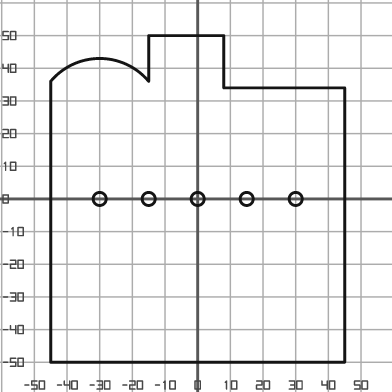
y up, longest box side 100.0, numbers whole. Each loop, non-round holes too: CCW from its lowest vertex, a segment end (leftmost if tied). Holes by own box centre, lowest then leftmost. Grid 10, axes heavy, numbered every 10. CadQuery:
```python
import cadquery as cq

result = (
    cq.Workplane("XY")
    .moveTo(-45.0, -50.0)
    .lineTo(45.0, -50.0)
    .lineTo(45.0, 34.0)
    .lineTo(8.0, 34.0)
    .lineTo(8.0, 50.0)
    .lineTo(-15.0, 50.0)
    .lineTo(-15.0, 36.0)
    .threePointArc((-30.0, 43.0), (-45.0, 36.0))
    .close()
    .moveTo(-30.0, 0.0)
    .circle(2.0)
    .moveTo(-15.0, 0.0)
    .circle(2.0)
    .moveTo(0.0, 0.0)
    .circle(2.0)
    .moveTo(15.0, 0.0)
    .circle(2.0)
    .moveTo(30.0, 0.0)
    .circle(2.0)
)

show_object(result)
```